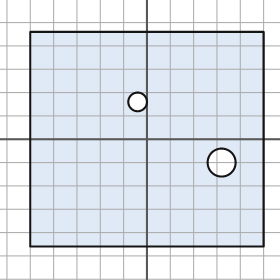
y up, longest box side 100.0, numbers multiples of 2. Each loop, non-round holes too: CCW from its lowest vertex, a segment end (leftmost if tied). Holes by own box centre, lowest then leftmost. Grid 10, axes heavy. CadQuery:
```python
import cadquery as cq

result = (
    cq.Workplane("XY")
    .moveTo(-50.0, -46.0)
    .lineTo(50.0, -46.0)
    .lineTo(50.0, 46.0)
    .lineTo(-50.0, 46.0)
    .close()
    .moveTo(32.0, -10.0)
    .circle(6.0)
    .moveTo(-4.0, 16.0)
    .circle(4.0)
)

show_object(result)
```